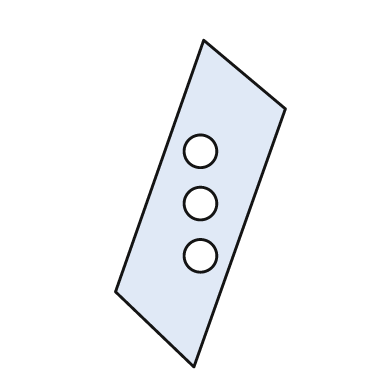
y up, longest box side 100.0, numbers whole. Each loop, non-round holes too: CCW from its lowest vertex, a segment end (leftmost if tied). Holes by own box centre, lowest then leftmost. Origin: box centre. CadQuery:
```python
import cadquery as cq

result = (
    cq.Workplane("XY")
    .moveTo(-2.0, -50.0)
    .lineTo(26.0, 29.0)
    .lineTo(1.0, 50.0)
    .lineTo(-26.0, -27.0)
    .close()
    .moveTo(0.0, -16.0)
    .circle(5.0)
    .moveTo(0.0, 0.0)
    .circle(5.0)
    .moveTo(0.0, 16.0)
    .circle(5.0)
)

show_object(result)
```